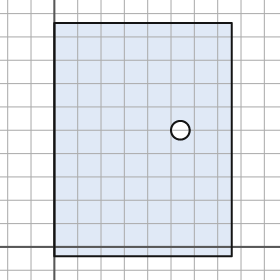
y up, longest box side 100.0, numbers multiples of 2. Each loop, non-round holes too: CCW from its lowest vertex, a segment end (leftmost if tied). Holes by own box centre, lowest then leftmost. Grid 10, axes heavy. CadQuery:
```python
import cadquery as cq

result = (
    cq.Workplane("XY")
    .moveTo(0.0, -4.0)
    .lineTo(76.0, -4.0)
    .lineTo(76.0, 96.0)
    .lineTo(0.0, 96.0)
    .close()
    .moveTo(54.0, 50.0)
    .circle(4.0)
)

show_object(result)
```